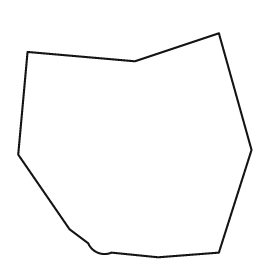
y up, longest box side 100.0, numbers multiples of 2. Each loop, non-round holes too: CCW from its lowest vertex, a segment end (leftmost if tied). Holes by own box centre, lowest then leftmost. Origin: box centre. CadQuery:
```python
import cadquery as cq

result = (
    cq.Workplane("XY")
    .moveTo(10.0, -48.0)
    .lineTo(36.0, -46.0)
    .lineTo(50.0, -2.0)
    .lineTo(36.0, 48.0)
    .lineTo(0.0, 36.0)
    .lineTo(-46.0, 40.0)
    .lineTo(-50.0, -4.0)
    .lineTo(-28.0, -36.0)
    .lineTo(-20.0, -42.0)
    .threePointArc((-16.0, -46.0), (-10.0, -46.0))
    .close()
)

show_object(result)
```